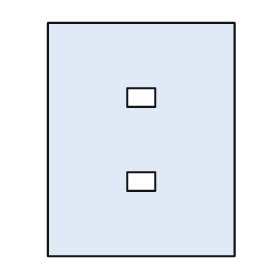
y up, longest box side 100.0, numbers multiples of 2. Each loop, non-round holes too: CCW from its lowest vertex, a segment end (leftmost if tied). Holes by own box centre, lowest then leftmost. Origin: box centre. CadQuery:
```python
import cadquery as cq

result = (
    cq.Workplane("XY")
    .moveTo(-40.0, -50.0)
    .lineTo(40.0, -50.0)
    .lineTo(40.0, 50.0)
    .lineTo(-40.0, 50.0)
    .close()
    .moveTo(-6.0, -22.0)
    .lineTo(6.0, -22.0)
    .lineTo(6.0, -14.0)
    .lineTo(-6.0, -14.0)
    .close()
    .moveTo(-6.0, 14.0)
    .lineTo(6.0, 14.0)
    .lineTo(6.0, 22.0)
    .lineTo(-6.0, 22.0)
    .close()
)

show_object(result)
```